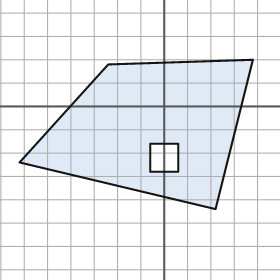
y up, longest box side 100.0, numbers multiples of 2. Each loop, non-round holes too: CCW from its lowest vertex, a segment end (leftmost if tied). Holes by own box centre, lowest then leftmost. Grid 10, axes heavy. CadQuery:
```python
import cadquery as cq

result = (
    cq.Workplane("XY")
    .moveTo(22.0, -44.0)
    .lineTo(38.0, 20.0)
    .lineTo(-24.0, 18.0)
    .lineTo(-62.0, -24.0)
    .close()
    .moveTo(-6.0, -28.0)
    .lineTo(6.0, -28.0)
    .lineTo(6.0, -16.0)
    .lineTo(-6.0, -16.0)
    .close()
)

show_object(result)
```